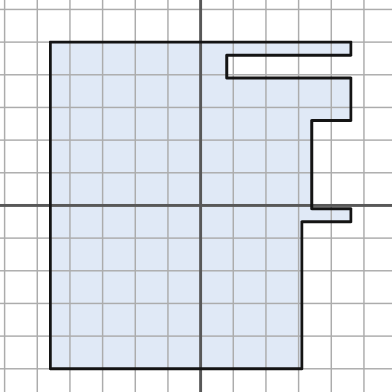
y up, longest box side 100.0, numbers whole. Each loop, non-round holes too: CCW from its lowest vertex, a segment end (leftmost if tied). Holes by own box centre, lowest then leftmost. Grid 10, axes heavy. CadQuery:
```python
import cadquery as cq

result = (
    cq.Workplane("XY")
    .moveTo(-46.0, -50.0)
    .lineTo(31.0, -50.0)
    .lineTo(31.0, -5.0)
    .lineTo(46.0, -5.0)
    .lineTo(46.0, -1.0)
    .lineTo(34.0, -1.0)
    .lineTo(34.0, 26.0)
    .lineTo(46.0, 26.0)
    .lineTo(46.0, 39.0)
    .lineTo(8.0, 39.0)
    .lineTo(8.0, 46.0)
    .lineTo(46.0, 46.0)
    .lineTo(46.0, 50.0)
    .lineTo(-46.0, 50.0)
    .close()
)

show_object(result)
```